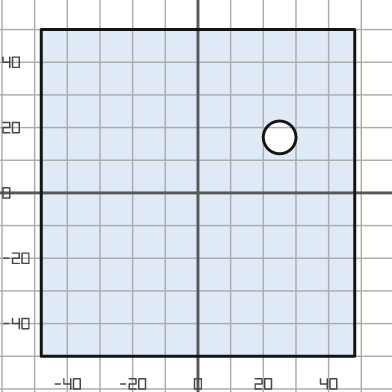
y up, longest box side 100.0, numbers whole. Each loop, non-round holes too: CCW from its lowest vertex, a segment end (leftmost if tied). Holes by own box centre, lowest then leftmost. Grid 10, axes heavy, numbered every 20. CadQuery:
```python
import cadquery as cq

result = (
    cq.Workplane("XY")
    .moveTo(-48.0, -50.0)
    .lineTo(48.0, -50.0)
    .lineTo(48.0, 50.0)
    .lineTo(-48.0, 50.0)
    .close()
    .moveTo(25.0, 17.0)
    .circle(5.0)
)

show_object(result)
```